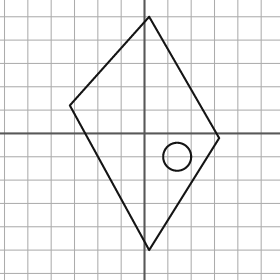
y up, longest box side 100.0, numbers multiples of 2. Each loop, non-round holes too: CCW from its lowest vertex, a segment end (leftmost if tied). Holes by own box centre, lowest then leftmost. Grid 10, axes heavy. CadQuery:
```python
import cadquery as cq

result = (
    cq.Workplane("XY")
    .moveTo(2.0, -50.0)
    .lineTo(32.0, -2.0)
    .lineTo(2.0, 50.0)
    .lineTo(-32.0, 12.0)
    .close()
    .moveTo(14.0, -10.0)
    .circle(6.0)
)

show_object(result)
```